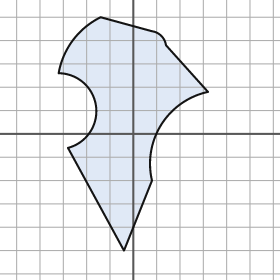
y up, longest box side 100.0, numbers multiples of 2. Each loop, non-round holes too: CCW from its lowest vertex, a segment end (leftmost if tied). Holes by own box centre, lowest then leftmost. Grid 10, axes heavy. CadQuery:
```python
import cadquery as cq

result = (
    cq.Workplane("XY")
    .moveTo(-4.0, -50.0)
    .lineTo(8.0, -20.0)
    .threePointArc((12.0, 4.0), (32.0, 18.0))
    .lineTo(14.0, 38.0)
    .threePointArc((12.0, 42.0), (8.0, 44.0))
    .lineTo(-14.0, 50.0)
    .threePointArc((-26.0, 40.0), (-32.0, 26.0))
    .threePointArc((-16.0, 12.0), (-28.0, -6.0))
    .close()
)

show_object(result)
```